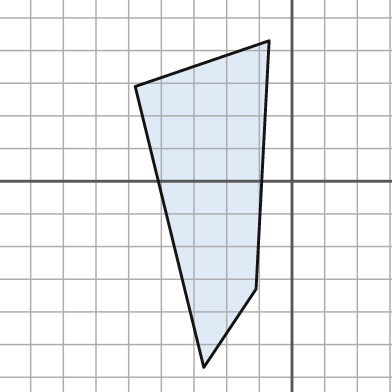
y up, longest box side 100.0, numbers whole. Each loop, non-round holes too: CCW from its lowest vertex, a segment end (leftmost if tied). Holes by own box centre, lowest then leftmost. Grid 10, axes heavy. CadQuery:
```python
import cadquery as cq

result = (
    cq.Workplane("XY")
    .moveTo(-27.0, -57.0)
    .lineTo(-11.0, -33.0)
    .lineTo(-7.0, 43.0)
    .lineTo(-48.0, 29.0)
    .close()
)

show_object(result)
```